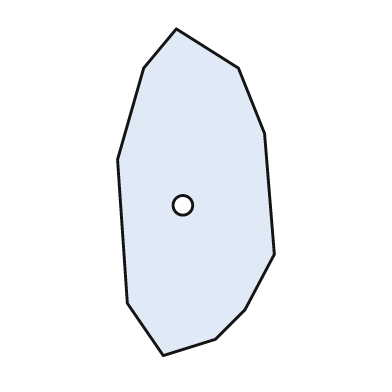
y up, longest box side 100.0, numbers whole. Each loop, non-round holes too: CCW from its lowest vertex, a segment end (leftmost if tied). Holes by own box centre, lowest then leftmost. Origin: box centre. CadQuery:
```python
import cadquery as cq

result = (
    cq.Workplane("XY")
    .moveTo(-10.0, -50.0)
    .lineTo(6.0, -45.0)
    .lineTo(15.0, -36.0)
    .lineTo(24.0, -19.0)
    .lineTo(21.0, 18.0)
    .lineTo(13.0, 38.0)
    .lineTo(-6.0, 50.0)
    .lineTo(-16.0, 38.0)
    .lineTo(-24.0, 10.0)
    .lineTo(-21.0, -34.0)
    .close()
    .moveTo(-4.0, -4.0)
    .circle(3.0)
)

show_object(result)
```